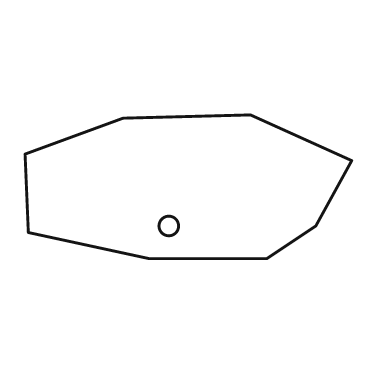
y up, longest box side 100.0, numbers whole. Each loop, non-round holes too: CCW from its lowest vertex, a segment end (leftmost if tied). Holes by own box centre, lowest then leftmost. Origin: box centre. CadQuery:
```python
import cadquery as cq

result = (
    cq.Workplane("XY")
    .moveTo(-12.0, -22.0)
    .lineTo(24.0, -22.0)
    .lineTo(39.0, -12.0)
    .lineTo(50.0, 8.0)
    .lineTo(19.0, 22.0)
    .lineTo(-20.0, 21.0)
    .lineTo(-50.0, 10.0)
    .lineTo(-49.0, -14.0)
    .close()
    .moveTo(-6.0, -12.0)
    .circle(3.0)
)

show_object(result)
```